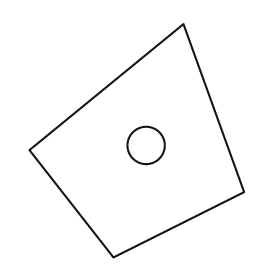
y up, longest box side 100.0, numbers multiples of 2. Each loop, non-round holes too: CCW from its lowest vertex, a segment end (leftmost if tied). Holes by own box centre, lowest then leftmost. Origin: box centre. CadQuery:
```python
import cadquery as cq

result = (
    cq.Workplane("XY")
    .moveTo(-10.0, -50.0)
    .lineTo(46.0, -22.0)
    .lineTo(20.0, 50.0)
    .lineTo(-46.0, -4.0)
    .close()
    .moveTo(4.0, -2.0)
    .circle(8.0)
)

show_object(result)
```